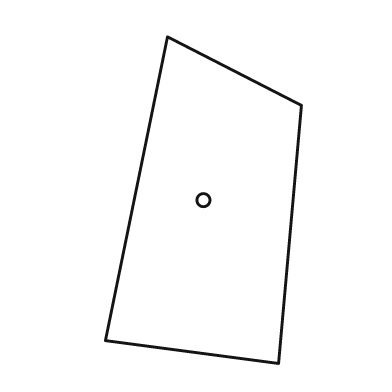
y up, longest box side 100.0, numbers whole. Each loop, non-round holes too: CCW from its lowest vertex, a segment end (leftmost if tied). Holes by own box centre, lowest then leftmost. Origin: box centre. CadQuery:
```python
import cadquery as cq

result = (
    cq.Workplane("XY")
    .moveTo(23.0, -50.0)
    .lineTo(30.0, 29.0)
    .lineTo(-11.0, 50.0)
    .lineTo(-30.0, -43.0)
    .close()
    .moveTo(0.0, 0.0)
    .circle(2.0)
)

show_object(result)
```